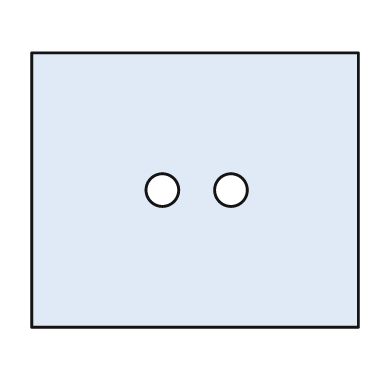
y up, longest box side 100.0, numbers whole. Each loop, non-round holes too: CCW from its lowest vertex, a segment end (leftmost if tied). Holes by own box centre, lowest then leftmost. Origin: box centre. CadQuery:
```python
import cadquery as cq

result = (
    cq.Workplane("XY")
    .moveTo(-50.0, -42.0)
    .lineTo(50.0, -42.0)
    .lineTo(50.0, 42.0)
    .lineTo(-50.0, 42.0)
    .close()
    .moveTo(-10.0, 0.0)
    .circle(5.0)
    .moveTo(11.0, 0.0)
    .circle(5.0)
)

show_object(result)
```